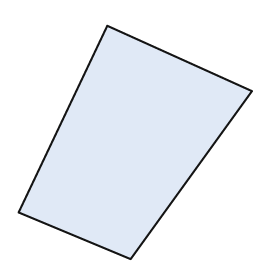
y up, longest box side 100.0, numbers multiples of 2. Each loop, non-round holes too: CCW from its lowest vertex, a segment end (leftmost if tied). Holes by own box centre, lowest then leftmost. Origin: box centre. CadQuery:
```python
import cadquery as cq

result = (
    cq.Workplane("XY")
    .moveTo(-2.0, -50.0)
    .lineTo(50.0, 22.0)
    .lineTo(-12.0, 50.0)
    .lineTo(-50.0, -30.0)
    .close()
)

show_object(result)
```